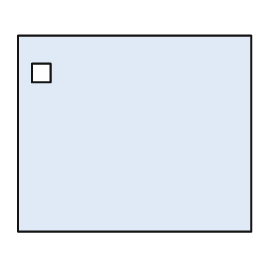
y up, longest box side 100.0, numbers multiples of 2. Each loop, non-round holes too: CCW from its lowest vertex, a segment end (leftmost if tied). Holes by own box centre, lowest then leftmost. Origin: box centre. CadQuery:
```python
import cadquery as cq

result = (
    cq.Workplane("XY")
    .moveTo(-50.0, -42.0)
    .lineTo(50.0, -42.0)
    .lineTo(50.0, 42.0)
    .lineTo(-50.0, 42.0)
    .close()
    .moveTo(-44.0, 22.0)
    .lineTo(-36.0, 22.0)
    .lineTo(-36.0, 30.0)
    .lineTo(-44.0, 30.0)
    .close()
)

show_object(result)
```